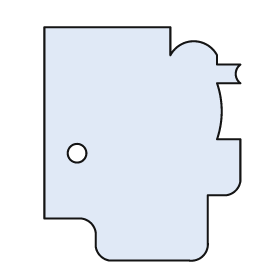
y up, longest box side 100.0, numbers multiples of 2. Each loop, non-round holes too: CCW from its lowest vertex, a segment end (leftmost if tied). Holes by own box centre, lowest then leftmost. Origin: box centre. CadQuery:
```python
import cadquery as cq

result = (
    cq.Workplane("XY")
    .moveTo(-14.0, -50.0)
    .lineTo(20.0, -50.0)
    .threePointArc((26.0, -48.0), (28.0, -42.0))
    .lineTo(28.0, -22.0)
    .lineTo(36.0, -22.0)
    .threePointArc((40.0, -20.0), (42.0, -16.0))
    .lineTo(42.0, 2.0)
    .lineTo(32.0, 2.0)
    .threePointArc((34.0, 14.0), (32.0, 26.0))
    .lineTo(42.0, 26.0)
    .threePointArc((40.0, 30.0), (42.0, 34.0))
    .lineTo(32.0, 34.0)
    .lineTo(32.0, 38.0)
    .threePointArc((22.0, 44.0), (12.0, 38.0))
    .lineTo(12.0, 50.0)
    .lineTo(-42.0, 50.0)
    .lineTo(-42.0, -32.0)
    .lineTo(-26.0, -32.0)
    .threePointArc((-22.0, -34.0), (-20.0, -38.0))
    .lineTo(-20.0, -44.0)
    .threePointArc((-18.0, -48.0), (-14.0, -50.0))
    .close()
    .moveTo(-28.0, -4.0)
    .circle(4.0)
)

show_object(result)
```